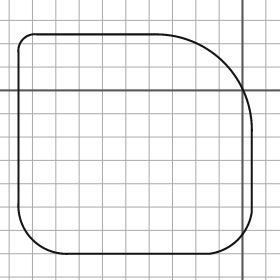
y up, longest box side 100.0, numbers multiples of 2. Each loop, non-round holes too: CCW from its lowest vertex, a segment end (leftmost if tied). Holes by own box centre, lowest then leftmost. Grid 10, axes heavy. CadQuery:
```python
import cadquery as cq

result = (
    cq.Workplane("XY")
    .moveTo(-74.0, -70.0)
    .lineTo(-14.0, -70.0)
    .threePointArc((-2.0, -64.0), (4.0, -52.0))
    .lineTo(4.0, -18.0)
    .threePointArc((-8.0, 12.0), (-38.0, 24.0))
    .lineTo(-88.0, 24.0)
    .threePointArc((-94.0, 22.0), (-96.0, 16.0))
    .lineTo(-96.0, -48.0)
    .threePointArc((-90.0, -64.0), (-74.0, -70.0))
    .close()
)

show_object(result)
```